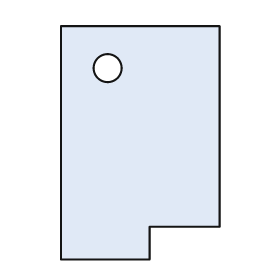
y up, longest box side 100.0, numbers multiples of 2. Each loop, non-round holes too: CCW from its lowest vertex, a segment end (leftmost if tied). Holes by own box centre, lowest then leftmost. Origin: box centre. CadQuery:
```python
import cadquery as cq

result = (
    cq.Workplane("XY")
    .moveTo(-34.0, -50.0)
    .lineTo(4.0, -50.0)
    .lineTo(4.0, -36.0)
    .lineTo(34.0, -36.0)
    .lineTo(34.0, 50.0)
    .lineTo(-34.0, 50.0)
    .close()
    .moveTo(-14.0, 32.0)
    .circle(6.0)
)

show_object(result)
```